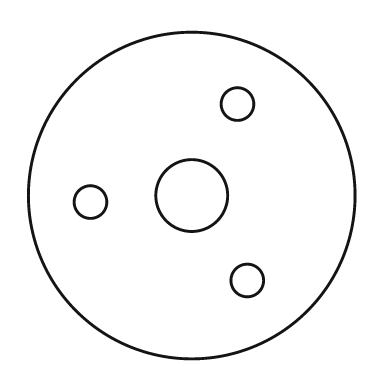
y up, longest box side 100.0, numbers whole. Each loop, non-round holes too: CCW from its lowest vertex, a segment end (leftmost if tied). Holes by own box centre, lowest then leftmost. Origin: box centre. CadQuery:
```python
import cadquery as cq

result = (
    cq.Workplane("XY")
    .moveTo(0.0, 0.0)
    .circle(50.0)
    .moveTo(17.0, -26.0)
    .circle(5.0)
    .moveTo(-31.0, -2.0)
    .circle(5.0)
    .moveTo(0.0, 0.0)
    .circle(11.0)
    .moveTo(14.0, 28.0)
    .circle(5.0)
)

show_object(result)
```